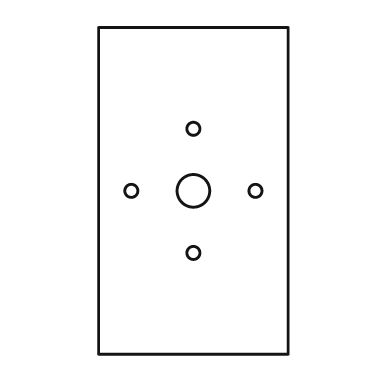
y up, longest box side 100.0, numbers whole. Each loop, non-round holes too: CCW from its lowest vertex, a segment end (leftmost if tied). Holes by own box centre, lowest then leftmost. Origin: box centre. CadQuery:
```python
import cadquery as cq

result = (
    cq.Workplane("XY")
    .moveTo(-29.0, -50.0)
    .lineTo(29.0, -50.0)
    .lineTo(29.0, 50.0)
    .lineTo(-29.0, 50.0)
    .close()
    .moveTo(0.0, -19.0)
    .circle(2.0)
    .moveTo(-19.0, 0.0)
    .circle(2.0)
    .moveTo(0.0, 0.0)
    .circle(5.0)
    .moveTo(19.0, 0.0)
    .circle(2.0)
    .moveTo(0.0, 19.0)
    .circle(2.0)
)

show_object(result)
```